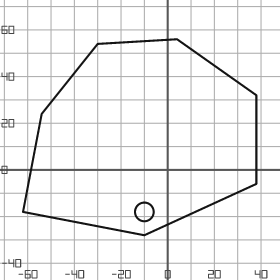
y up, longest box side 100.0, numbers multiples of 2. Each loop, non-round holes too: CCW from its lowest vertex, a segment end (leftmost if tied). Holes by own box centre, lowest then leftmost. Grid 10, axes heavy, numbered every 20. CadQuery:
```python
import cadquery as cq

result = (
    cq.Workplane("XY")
    .moveTo(-10.0, -28.0)
    .lineTo(38.0, -6.0)
    .lineTo(38.0, 32.0)
    .lineTo(4.0, 56.0)
    .lineTo(-30.0, 54.0)
    .lineTo(-54.0, 24.0)
    .lineTo(-62.0, -18.0)
    .close()
    .moveTo(-10.0, -18.0)
    .circle(4.0)
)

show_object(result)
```